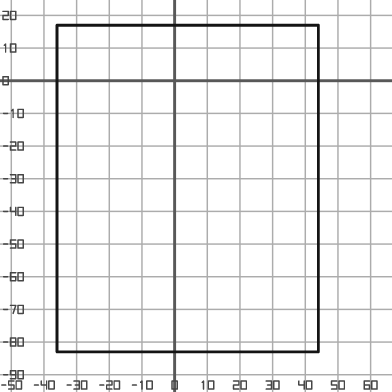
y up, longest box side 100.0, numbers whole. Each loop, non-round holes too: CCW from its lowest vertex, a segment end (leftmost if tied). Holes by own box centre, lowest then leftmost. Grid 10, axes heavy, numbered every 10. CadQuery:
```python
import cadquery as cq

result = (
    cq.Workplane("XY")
    .moveTo(-36.0, -83.0)
    .lineTo(44.0, -83.0)
    .lineTo(44.0, 17.0)
    .lineTo(-36.0, 17.0)
    .close()
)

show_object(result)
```